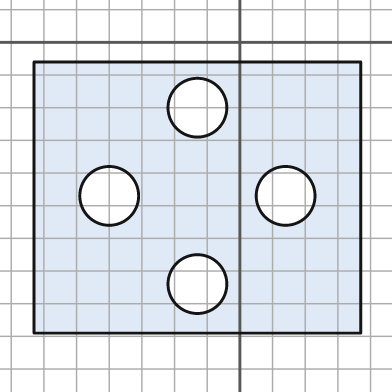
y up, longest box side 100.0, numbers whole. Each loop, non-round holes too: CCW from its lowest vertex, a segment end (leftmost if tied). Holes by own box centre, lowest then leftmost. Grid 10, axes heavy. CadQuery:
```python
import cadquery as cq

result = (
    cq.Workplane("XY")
    .moveTo(-63.0, -89.0)
    .lineTo(37.0, -89.0)
    .lineTo(37.0, -6.0)
    .lineTo(-63.0, -6.0)
    .close()
    .moveTo(-13.0, -74.0)
    .circle(9.0)
    .moveTo(-40.0, -47.0)
    .circle(9.0)
    .moveTo(14.0, -47.0)
    .circle(9.0)
    .moveTo(-13.0, -20.0)
    .circle(9.0)
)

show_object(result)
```